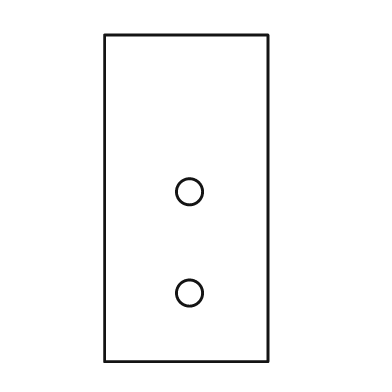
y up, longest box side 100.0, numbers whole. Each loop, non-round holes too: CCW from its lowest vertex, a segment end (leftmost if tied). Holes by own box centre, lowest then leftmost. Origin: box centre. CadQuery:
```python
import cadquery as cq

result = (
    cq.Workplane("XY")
    .moveTo(-25.0, -50.0)
    .lineTo(25.0, -50.0)
    .lineTo(25.0, 50.0)
    .lineTo(-25.0, 50.0)
    .close()
    .moveTo(1.0, -29.0)
    .circle(4.0)
    .moveTo(1.0, 2.0)
    .circle(4.0)
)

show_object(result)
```